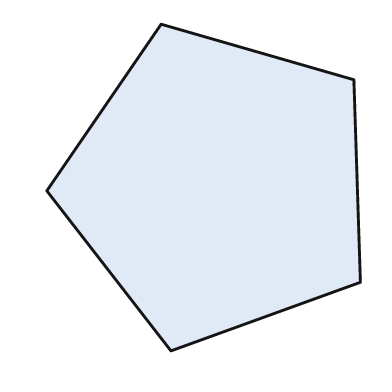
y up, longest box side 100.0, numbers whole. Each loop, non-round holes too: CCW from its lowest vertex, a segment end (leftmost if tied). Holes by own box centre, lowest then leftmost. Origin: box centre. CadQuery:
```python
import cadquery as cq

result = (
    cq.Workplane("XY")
    .moveTo(-10.0, -50.0)
    .lineTo(48.0, -29.0)
    .lineTo(46.0, 33.0)
    .lineTo(-13.0, 50.0)
    .lineTo(-48.0, -1.0)
    .close()
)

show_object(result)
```